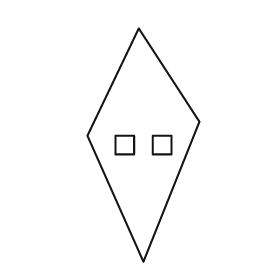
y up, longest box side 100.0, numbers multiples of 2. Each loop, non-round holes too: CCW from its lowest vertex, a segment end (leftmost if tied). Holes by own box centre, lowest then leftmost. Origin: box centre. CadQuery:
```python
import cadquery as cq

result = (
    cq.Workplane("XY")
    .moveTo(0.0, -50.0)
    .lineTo(24.0, 10.0)
    .lineTo(-2.0, 50.0)
    .lineTo(-24.0, 4.0)
    .close()
    .moveTo(-12.0, -4.0)
    .lineTo(-4.0, -4.0)
    .lineTo(-4.0, 4.0)
    .lineTo(-12.0, 4.0)
    .close()
    .moveTo(4.0, -4.0)
    .lineTo(12.0, -4.0)
    .lineTo(12.0, 4.0)
    .lineTo(4.0, 4.0)
    .close()
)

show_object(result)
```